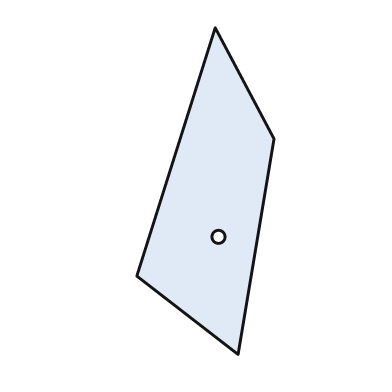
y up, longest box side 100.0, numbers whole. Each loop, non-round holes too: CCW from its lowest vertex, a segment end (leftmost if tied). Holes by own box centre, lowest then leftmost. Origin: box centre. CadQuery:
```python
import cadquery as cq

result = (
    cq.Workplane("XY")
    .moveTo(10.0, -50.0)
    .lineTo(21.0, 16.0)
    .lineTo(3.0, 50.0)
    .lineTo(-21.0, -26.0)
    .close()
    .moveTo(4.0, -14.0)
    .circle(2.0)
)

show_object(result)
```